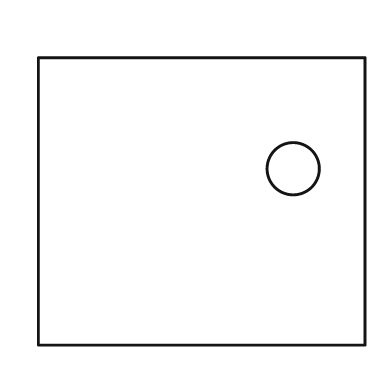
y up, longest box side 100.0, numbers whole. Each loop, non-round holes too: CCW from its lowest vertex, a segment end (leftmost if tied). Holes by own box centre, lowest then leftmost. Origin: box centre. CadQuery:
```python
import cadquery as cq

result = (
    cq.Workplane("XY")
    .moveTo(-50.0, -44.0)
    .lineTo(50.0, -44.0)
    .lineTo(50.0, 44.0)
    .lineTo(-50.0, 44.0)
    .close()
    .moveTo(28.0, 10.0)
    .circle(8.0)
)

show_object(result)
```